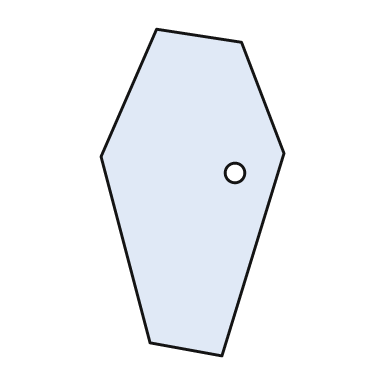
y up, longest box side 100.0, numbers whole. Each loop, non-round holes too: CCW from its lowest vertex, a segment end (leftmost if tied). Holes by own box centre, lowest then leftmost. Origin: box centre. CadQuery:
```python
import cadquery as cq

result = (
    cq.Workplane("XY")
    .moveTo(9.0, -50.0)
    .lineTo(28.0, 12.0)
    .lineTo(15.0, 46.0)
    .lineTo(-11.0, 50.0)
    .lineTo(-28.0, 11.0)
    .lineTo(-13.0, -46.0)
    .close()
    .moveTo(13.0, 6.0)
    .circle(3.0)
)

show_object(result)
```